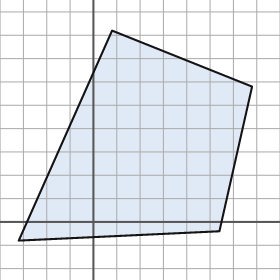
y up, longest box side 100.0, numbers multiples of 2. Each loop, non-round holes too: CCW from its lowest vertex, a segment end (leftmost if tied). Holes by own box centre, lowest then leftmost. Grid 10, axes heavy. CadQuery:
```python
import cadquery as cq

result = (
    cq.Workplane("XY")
    .moveTo(-32.0, -8.0)
    .lineTo(54.0, -4.0)
    .lineTo(68.0, 58.0)
    .lineTo(8.0, 82.0)
    .close()
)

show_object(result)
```